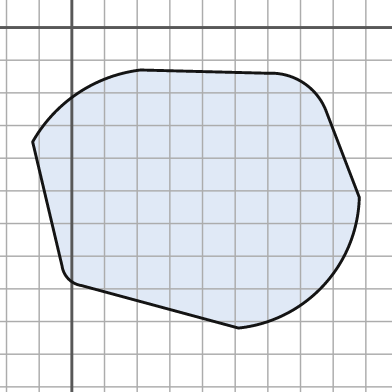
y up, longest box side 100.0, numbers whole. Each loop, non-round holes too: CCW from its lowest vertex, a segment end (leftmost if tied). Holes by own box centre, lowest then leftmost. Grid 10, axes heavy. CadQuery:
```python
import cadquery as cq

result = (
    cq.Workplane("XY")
    .moveTo(51.0, -92.0)
    .threePointArc((77.0, -79.0), (88.0, -52.0))
    .lineTo(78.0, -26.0)
    .threePointArc((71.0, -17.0), (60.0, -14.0))
    .lineTo(21.0, -13.0)
    .threePointArc((2.0, -20.0), (-12.0, -35.0))
    .lineTo(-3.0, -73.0)
    .threePointArc((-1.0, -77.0), (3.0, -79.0))
    .close()
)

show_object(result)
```